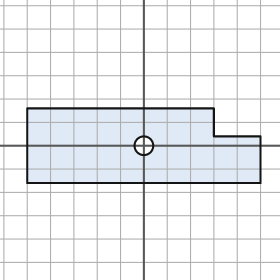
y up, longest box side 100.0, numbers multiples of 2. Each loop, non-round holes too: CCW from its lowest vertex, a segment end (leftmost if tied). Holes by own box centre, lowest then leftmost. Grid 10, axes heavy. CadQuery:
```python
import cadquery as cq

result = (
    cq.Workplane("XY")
    .moveTo(-50.0, -16.0)
    .lineTo(50.0, -16.0)
    .lineTo(50.0, 4.0)
    .lineTo(30.0, 4.0)
    .lineTo(30.0, 16.0)
    .lineTo(-50.0, 16.0)
    .close()
    .moveTo(0.0, 0.0)
    .circle(4.0)
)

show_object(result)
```